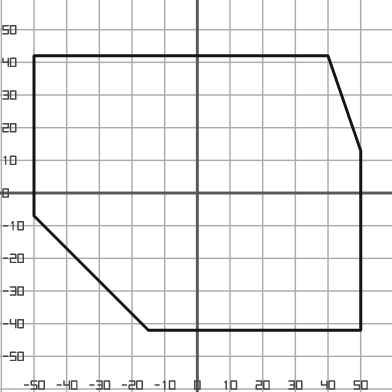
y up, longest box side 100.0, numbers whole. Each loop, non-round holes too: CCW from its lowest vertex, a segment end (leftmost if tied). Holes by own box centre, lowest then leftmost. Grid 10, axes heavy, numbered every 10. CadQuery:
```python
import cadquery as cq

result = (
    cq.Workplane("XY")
    .moveTo(-15.0, -42.0)
    .lineTo(50.0, -42.0)
    .lineTo(50.0, 13.0)
    .lineTo(40.0, 42.0)
    .lineTo(-50.0, 42.0)
    .lineTo(-50.0, -7.0)
    .close()
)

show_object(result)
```